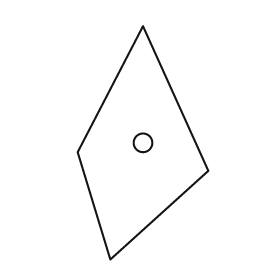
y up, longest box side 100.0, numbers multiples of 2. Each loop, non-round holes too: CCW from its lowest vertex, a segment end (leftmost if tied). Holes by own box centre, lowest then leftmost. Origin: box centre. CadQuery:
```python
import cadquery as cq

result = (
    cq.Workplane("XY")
    .moveTo(-14.0, -50.0)
    .lineTo(28.0, -12.0)
    .lineTo(0.0, 50.0)
    .lineTo(-28.0, -4.0)
    .close()
    .moveTo(0.0, 0.0)
    .circle(4.0)
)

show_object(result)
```